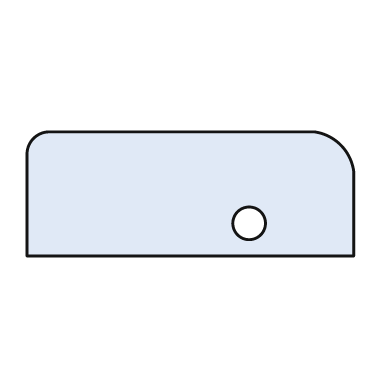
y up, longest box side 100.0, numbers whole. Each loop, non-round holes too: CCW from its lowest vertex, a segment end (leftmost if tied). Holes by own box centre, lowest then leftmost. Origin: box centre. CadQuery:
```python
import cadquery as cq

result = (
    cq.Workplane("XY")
    .moveTo(-50.0, -19.0)
    .lineTo(50.0, -19.0)
    .lineTo(50.0, 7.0)
    .threePointArc((46.0, 15.0), (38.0, 19.0))
    .lineTo(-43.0, 19.0)
    .threePointArc((-48.0, 17.0), (-50.0, 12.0))
    .close()
    .moveTo(18.0, -9.0)
    .circle(5.0)
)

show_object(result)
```